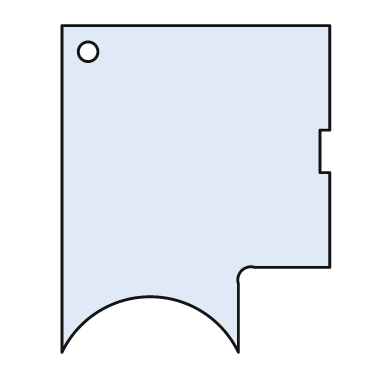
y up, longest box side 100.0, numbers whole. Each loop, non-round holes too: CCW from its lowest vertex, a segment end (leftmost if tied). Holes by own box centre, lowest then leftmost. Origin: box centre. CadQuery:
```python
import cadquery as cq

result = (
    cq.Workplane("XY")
    .moveTo(-41.0, -50.0)
    .threePointArc((-14.0, -33.0), (13.0, -50.0))
    .lineTo(13.0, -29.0)
    .threePointArc((14.0, -25.0), (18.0, -24.0))
    .lineTo(41.0, -24.0)
    .lineTo(41.0, 5.0)
    .lineTo(38.0, 5.0)
    .lineTo(38.0, 18.0)
    .lineTo(41.0, 18.0)
    .lineTo(41.0, 50.0)
    .lineTo(-41.0, 50.0)
    .close()
    .moveTo(-33.0, 42.0)
    .circle(3.0)
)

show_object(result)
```